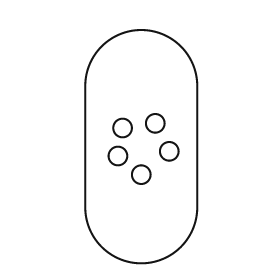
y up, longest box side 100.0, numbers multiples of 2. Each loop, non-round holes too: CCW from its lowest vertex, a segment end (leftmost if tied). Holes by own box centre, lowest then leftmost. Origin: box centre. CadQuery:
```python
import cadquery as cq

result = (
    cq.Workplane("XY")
    .moveTo(-24.0, -26.0)
    .threePointArc((0.0, -50.0), (24.0, -26.0))
    .lineTo(24.0, 26.0)
    .threePointArc((0.0, 50.0), (-24.0, 26.0))
    .close()
    .moveTo(0.0, -12.0)
    .circle(4.0)
    .moveTo(-10.0, -4.0)
    .circle(4.0)
    .moveTo(12.0, -2.0)
    .circle(4.0)
    .moveTo(-8.0, 8.0)
    .circle(4.0)
    .moveTo(6.0, 10.0)
    .circle(4.0)
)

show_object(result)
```